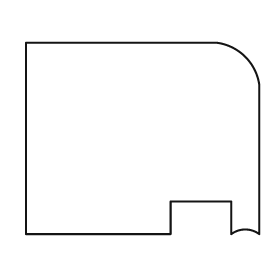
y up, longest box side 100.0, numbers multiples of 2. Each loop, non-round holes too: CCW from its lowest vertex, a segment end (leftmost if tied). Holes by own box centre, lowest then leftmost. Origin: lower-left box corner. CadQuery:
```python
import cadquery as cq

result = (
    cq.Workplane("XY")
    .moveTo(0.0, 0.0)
    .lineTo(62.0, 0.0)
    .lineTo(62.0, 14.0)
    .lineTo(88.0, 14.0)
    .lineTo(88.0, 0.0)
    .threePointArc((94.0, 2.0), (100.0, 0.0))
    .lineTo(100.0, 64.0)
    .threePointArc((94.0, 76.0), (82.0, 82.0))
    .lineTo(0.0, 82.0)
    .close()
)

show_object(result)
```